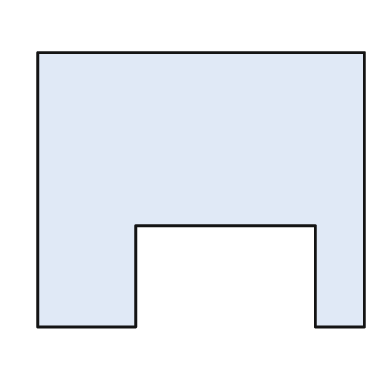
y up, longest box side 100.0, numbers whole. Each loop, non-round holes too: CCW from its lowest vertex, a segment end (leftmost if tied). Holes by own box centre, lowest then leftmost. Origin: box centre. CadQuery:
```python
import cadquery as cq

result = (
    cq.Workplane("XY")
    .moveTo(-50.0, -42.0)
    .lineTo(-20.0, -42.0)
    .lineTo(-20.0, -11.0)
    .lineTo(35.0, -11.0)
    .lineTo(35.0, -42.0)
    .lineTo(50.0, -42.0)
    .lineTo(50.0, 42.0)
    .lineTo(-50.0, 42.0)
    .close()
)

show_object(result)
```